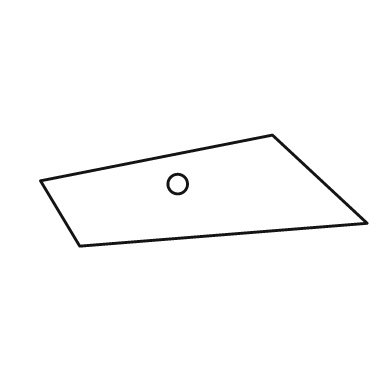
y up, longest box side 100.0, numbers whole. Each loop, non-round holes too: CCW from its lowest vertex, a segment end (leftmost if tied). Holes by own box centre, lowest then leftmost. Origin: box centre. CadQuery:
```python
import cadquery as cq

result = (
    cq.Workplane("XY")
    .moveTo(-38.0, -17.0)
    .lineTo(50.0, -10.0)
    .lineTo(21.0, 17.0)
    .lineTo(-50.0, 3.0)
    .close()
    .moveTo(-8.0, 2.0)
    .circle(3.0)
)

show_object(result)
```